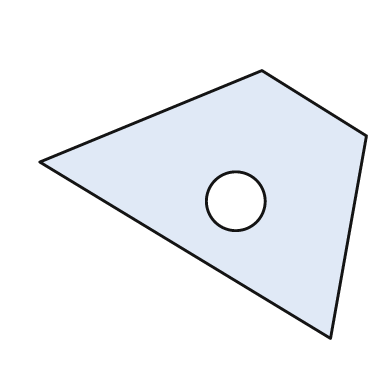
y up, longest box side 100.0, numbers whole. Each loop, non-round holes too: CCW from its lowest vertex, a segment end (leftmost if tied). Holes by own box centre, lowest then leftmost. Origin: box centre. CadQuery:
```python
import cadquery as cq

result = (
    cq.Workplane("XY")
    .moveTo(39.0, -41.0)
    .lineTo(50.0, 21.0)
    .lineTo(18.0, 41.0)
    .lineTo(-50.0, 13.0)
    .close()
    .moveTo(10.0, 1.0)
    .circle(9.0)
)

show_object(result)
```